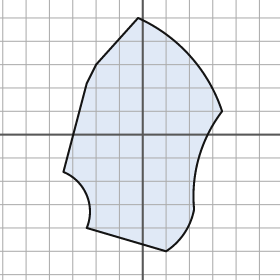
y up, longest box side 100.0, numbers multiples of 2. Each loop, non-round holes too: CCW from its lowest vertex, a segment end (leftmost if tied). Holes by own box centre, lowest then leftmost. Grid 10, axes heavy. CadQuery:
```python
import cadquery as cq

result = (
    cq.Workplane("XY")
    .moveTo(10.0, -50.0)
    .threePointArc((18.0, -42.0), (22.0, -32.0))
    .threePointArc((24.0, -10.0), (34.0, 10.0))
    .threePointArc((20.0, 34.0), (-2.0, 50.0))
    .lineTo(-20.0, 30.0)
    .lineTo(-24.0, 22.0)
    .lineTo(-34.0, -16.0)
    .threePointArc((-24.0, -26.0), (-24.0, -40.0))
    .close()
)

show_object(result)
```